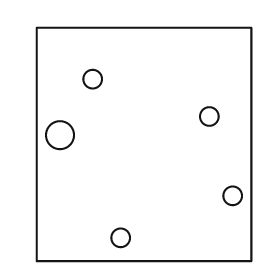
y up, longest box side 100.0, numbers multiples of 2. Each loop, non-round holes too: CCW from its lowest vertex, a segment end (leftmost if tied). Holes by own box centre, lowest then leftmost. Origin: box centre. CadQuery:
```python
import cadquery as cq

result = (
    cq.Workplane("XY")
    .moveTo(-46.0, -50.0)
    .lineTo(46.0, -50.0)
    .lineTo(46.0, 50.0)
    .lineTo(-46.0, 50.0)
    .close()
    .moveTo(-10.0, -40.0)
    .circle(4.0)
    .moveTo(38.0, -22.0)
    .circle(4.0)
    .moveTo(-36.0, 4.0)
    .circle(6.0)
    .moveTo(28.0, 12.0)
    .circle(4.0)
    .moveTo(-22.0, 28.0)
    .circle(4.0)
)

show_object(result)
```